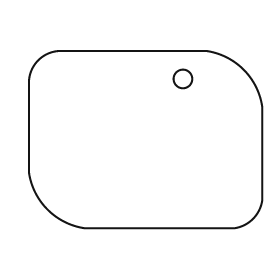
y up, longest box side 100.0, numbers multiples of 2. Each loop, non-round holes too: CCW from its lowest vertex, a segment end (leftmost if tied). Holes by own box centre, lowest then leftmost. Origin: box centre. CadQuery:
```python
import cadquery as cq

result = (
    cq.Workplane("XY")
    .moveTo(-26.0, -38.0)
    .lineTo(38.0, -38.0)
    .threePointArc((46.0, -34.0), (50.0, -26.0))
    .lineTo(50.0, 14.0)
    .threePointArc((42.0, 30.0), (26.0, 38.0))
    .lineTo(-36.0, 38.0)
    .threePointArc((-46.0, 34.0), (-50.0, 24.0))
    .lineTo(-50.0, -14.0)
    .threePointArc((-42.0, -30.0), (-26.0, -38.0))
    .close()
    .moveTo(16.0, 26.0)
    .circle(4.0)
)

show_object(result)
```